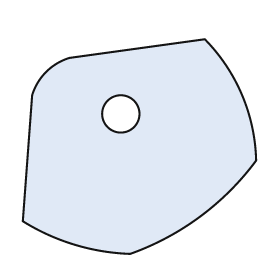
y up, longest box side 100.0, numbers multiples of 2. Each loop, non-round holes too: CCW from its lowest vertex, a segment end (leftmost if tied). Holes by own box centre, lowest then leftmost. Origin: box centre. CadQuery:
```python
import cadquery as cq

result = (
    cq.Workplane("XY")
    .moveTo(-4.0, -46.0)
    .threePointArc((26.0, -30.0), (50.0, -6.0))
    .threePointArc((44.0, 22.0), (28.0, 46.0))
    .lineTo(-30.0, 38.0)
    .threePointArc((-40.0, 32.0), (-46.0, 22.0))
    .lineTo(-50.0, -32.0)
    .threePointArc((-28.0, -42.0), (-4.0, -46.0))
    .close()
    .moveTo(-8.0, 14.0)
    .circle(8.0)
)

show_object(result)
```